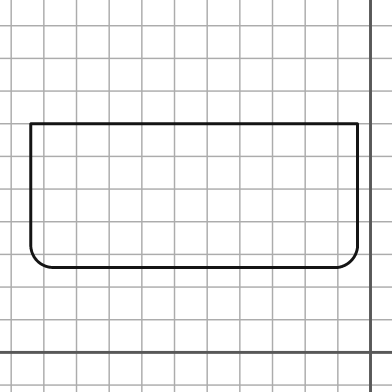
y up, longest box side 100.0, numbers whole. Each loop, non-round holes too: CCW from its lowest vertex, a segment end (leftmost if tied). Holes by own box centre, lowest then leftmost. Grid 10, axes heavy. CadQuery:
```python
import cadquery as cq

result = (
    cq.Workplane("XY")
    .moveTo(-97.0, 26.0)
    .lineTo(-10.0, 26.0)
    .threePointArc((-6.0, 28.0), (-4.0, 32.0))
    .lineTo(-4.0, 70.0)
    .lineTo(-104.0, 70.0)
    .lineTo(-104.0, 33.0)
    .threePointArc((-102.0, 28.0), (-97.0, 26.0))
    .close()
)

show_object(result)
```